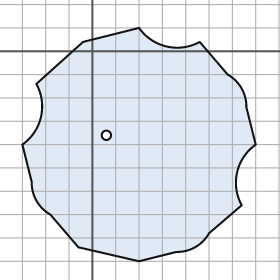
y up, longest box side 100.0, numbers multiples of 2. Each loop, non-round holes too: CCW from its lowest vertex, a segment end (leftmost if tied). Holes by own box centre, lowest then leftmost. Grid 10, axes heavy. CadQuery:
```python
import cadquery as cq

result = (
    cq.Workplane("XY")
    .moveTo(20.0, -90.0)
    .lineTo(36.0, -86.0)
    .threePointArc((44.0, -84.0), (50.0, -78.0))
    .lineTo(64.0, -66.0)
    .threePointArc((62.0, -52.0), (70.0, -40.0))
    .lineTo(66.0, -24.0)
    .threePointArc((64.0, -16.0), (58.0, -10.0))
    .lineTo(46.0, 4.0)
    .threePointArc((32.0, 2.0), (20.0, 10.0))
    .lineTo(-4.0, 4.0)
    .lineTo(-24.0, -14.0)
    .threePointArc((-22.0, -28.0), (-30.0, -40.0))
    .lineTo(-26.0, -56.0)
    .threePointArc((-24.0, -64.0), (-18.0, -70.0))
    .lineTo(-6.0, -84.0)
    .close()
    .moveTo(6.0, -36.0)
    .circle(2.0)
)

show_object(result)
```